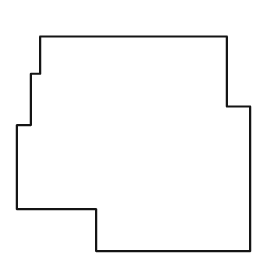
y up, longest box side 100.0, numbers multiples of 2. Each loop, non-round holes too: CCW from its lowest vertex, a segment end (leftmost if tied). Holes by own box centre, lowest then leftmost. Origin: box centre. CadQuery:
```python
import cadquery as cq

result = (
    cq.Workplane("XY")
    .moveTo(-16.0, -46.0)
    .lineTo(50.0, -46.0)
    .lineTo(50.0, 16.0)
    .lineTo(40.0, 16.0)
    .lineTo(40.0, 46.0)
    .lineTo(-40.0, 46.0)
    .lineTo(-40.0, 30.0)
    .lineTo(-44.0, 30.0)
    .lineTo(-44.0, 8.0)
    .lineTo(-50.0, 8.0)
    .lineTo(-50.0, -28.0)
    .lineTo(-16.0, -28.0)
    .close()
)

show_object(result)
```